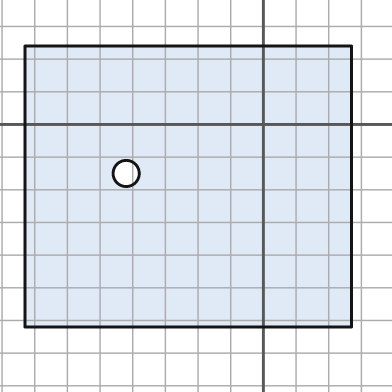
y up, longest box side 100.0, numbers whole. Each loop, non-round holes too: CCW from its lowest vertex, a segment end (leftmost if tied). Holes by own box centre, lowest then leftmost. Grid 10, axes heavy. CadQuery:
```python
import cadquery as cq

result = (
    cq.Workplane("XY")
    .moveTo(-73.0, -62.0)
    .lineTo(27.0, -62.0)
    .lineTo(27.0, 24.0)
    .lineTo(-73.0, 24.0)
    .close()
    .moveTo(-42.0, -15.0)
    .circle(4.0)
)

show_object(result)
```